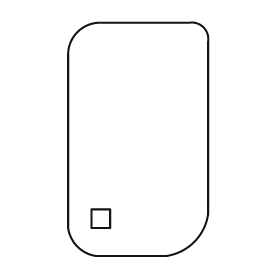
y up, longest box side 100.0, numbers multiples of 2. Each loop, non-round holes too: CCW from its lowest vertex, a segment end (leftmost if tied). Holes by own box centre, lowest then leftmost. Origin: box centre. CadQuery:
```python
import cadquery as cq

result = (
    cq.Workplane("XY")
    .moveTo(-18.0, -50.0)
    .lineTo(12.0, -50.0)
    .threePointArc((24.0, -44.0), (30.0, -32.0))
    .lineTo(30.0, 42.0)
    .threePointArc((28.0, 48.0), (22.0, 50.0))
    .lineTo(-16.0, 50.0)
    .threePointArc((-26.0, 46.0), (-30.0, 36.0))
    .lineTo(-30.0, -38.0)
    .threePointArc((-26.0, -46.0), (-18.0, -50.0))
    .close()
    .moveTo(-20.0, -38.0)
    .lineTo(-12.0, -38.0)
    .lineTo(-12.0, -30.0)
    .lineTo(-20.0, -30.0)
    .close()
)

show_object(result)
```